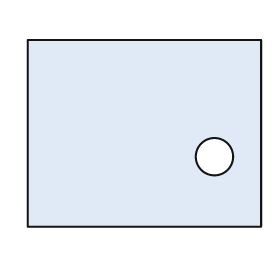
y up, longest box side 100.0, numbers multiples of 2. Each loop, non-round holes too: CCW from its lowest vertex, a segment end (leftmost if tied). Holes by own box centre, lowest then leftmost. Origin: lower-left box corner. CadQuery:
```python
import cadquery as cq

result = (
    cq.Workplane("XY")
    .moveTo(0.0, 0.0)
    .lineTo(100.0, 0.0)
    .lineTo(100.0, 80.0)
    .lineTo(0.0, 80.0)
    .close()
    .moveTo(80.0, 30.0)
    .circle(8.0)
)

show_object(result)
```